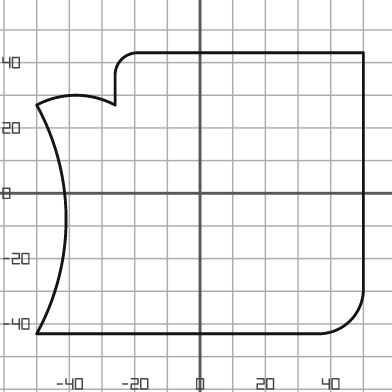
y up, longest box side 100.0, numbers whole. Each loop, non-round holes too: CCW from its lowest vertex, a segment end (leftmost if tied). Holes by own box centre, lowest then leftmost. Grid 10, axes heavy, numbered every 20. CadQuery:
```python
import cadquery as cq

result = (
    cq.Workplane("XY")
    .moveTo(-50.0, -43.0)
    .lineTo(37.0, -43.0)
    .threePointArc((46.0, -39.0), (50.0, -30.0))
    .lineTo(50.0, 43.0)
    .lineTo(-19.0, 43.0)
    .threePointArc((-24.0, 41.0), (-26.0, 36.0))
    .lineTo(-26.0, 27.0)
    .threePointArc((-38.0, 30.0), (-50.0, 27.0))
    .threePointArc((-41.0, -8.0), (-50.0, -43.0))
    .close()
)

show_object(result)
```